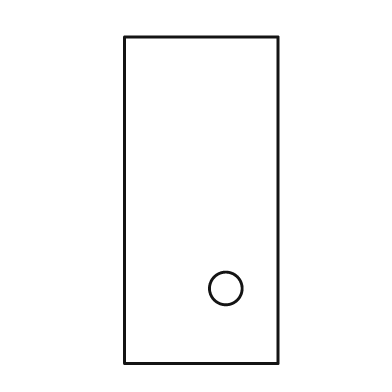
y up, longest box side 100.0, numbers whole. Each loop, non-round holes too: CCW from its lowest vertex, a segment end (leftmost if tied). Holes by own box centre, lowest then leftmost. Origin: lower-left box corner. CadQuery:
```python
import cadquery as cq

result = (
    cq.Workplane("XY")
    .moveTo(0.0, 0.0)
    .lineTo(47.0, 0.0)
    .lineTo(47.0, 100.0)
    .lineTo(0.0, 100.0)
    .close()
    .moveTo(31.0, 23.0)
    .circle(5.0)
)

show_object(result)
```